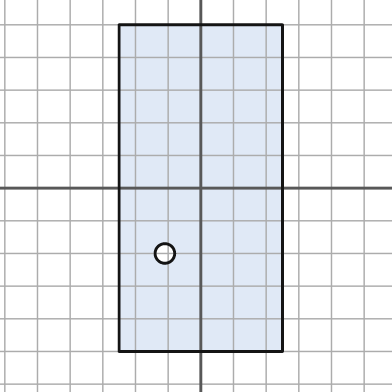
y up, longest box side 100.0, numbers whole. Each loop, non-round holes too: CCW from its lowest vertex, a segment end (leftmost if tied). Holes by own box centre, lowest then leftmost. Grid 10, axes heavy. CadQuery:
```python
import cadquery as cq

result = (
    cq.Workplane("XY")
    .moveTo(-25.0, -50.0)
    .lineTo(25.0, -50.0)
    .lineTo(25.0, 50.0)
    .lineTo(-25.0, 50.0)
    .close()
    .moveTo(-11.0, -20.0)
    .circle(3.0)
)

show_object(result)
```